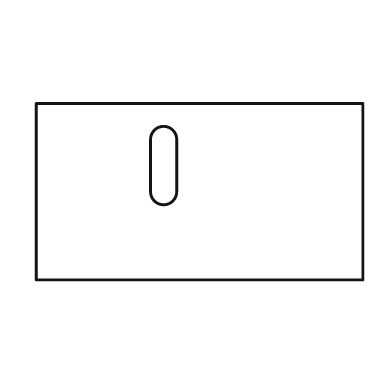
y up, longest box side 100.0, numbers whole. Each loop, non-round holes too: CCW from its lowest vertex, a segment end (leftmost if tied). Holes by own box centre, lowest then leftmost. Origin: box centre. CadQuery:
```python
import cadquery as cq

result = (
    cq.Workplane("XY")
    .moveTo(-50.0, -27.0)
    .lineTo(50.0, -27.0)
    .lineTo(50.0, 27.0)
    .lineTo(-50.0, 27.0)
    .close()
    .moveTo(-15.0, 0.0)
    .threePointArc((-11.0, -4.0), (-7.0, 0.0))
    .lineTo(-7.0, 16.0)
    .threePointArc((-11.0, 20.0), (-15.0, 16.0))
    .close()
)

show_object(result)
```